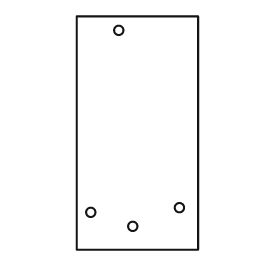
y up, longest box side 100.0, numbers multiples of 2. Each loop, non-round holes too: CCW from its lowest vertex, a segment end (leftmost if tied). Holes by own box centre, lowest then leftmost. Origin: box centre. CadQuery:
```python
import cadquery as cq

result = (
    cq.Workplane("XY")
    .moveTo(-26.0, -50.0)
    .lineTo(26.0, -50.0)
    .lineTo(26.0, 50.0)
    .lineTo(-26.0, 50.0)
    .close()
    .moveTo(-2.0, -40.0)
    .circle(2.0)
    .moveTo(-20.0, -34.0)
    .circle(2.0)
    .moveTo(18.0, -32.0)
    .circle(2.0)
    .moveTo(-8.0, 44.0)
    .circle(2.0)
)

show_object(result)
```